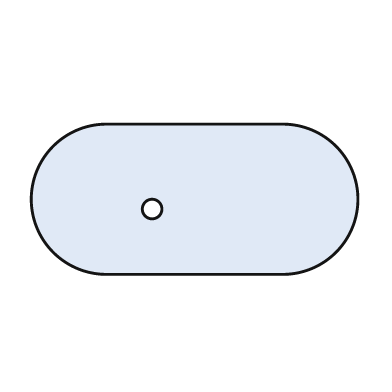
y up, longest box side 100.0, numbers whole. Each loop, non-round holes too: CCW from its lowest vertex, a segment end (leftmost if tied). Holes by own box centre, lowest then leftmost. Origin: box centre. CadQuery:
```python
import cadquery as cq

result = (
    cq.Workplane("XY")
    .moveTo(-27.0, -23.0)
    .lineTo(27.0, -23.0)
    .threePointArc((50.0, 0.0), (27.0, 23.0))
    .lineTo(-27.0, 23.0)
    .threePointArc((-50.0, 0.0), (-27.0, -23.0))
    .close()
    .moveTo(-13.0, -3.0)
    .circle(3.0)
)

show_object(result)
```